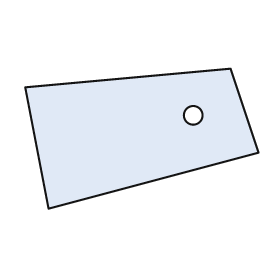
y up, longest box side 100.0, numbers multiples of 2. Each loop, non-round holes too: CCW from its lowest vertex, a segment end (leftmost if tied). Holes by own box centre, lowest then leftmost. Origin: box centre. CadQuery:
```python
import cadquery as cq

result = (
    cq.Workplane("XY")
    .moveTo(-40.0, -30.0)
    .lineTo(50.0, -6.0)
    .lineTo(38.0, 30.0)
    .lineTo(-50.0, 22.0)
    .close()
    .moveTo(22.0, 10.0)
    .circle(4.0)
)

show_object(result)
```